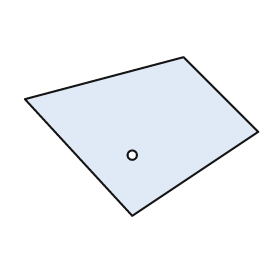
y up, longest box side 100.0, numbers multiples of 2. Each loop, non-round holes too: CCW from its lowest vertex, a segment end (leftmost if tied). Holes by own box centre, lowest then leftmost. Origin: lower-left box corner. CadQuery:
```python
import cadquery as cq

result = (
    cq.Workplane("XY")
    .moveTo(46.0, 0.0)
    .lineTo(100.0, 36.0)
    .lineTo(68.0, 68.0)
    .lineTo(0.0, 50.0)
    .close()
    .moveTo(46.0, 26.0)
    .circle(2.0)
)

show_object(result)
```